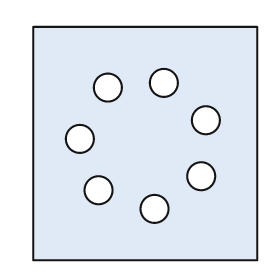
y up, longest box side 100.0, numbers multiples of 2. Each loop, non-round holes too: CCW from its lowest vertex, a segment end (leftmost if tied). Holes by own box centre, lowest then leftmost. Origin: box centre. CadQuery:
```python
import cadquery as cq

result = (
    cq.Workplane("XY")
    .moveTo(-48.0, -50.0)
    .lineTo(48.0, -50.0)
    .lineTo(48.0, 50.0)
    .lineTo(-48.0, 50.0)
    .close()
    .moveTo(4.0, -28.0)
    .circle(6.0)
    .moveTo(-20.0, -20.0)
    .circle(6.0)
    .moveTo(24.0, -14.0)
    .circle(6.0)
    .moveTo(-28.0, 2.0)
    .circle(6.0)
    .moveTo(26.0, 10.0)
    .circle(6.0)
    .moveTo(-16.0, 24.0)
    .circle(6.0)
    .moveTo(8.0, 26.0)
    .circle(6.0)
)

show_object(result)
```